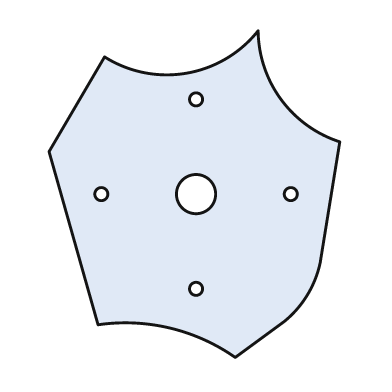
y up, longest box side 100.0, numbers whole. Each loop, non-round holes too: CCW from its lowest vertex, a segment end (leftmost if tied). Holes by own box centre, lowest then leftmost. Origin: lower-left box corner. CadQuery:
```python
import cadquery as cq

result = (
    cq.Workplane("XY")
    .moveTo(57.0, 0.0)
    .lineTo(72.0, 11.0)
    .threePointArc((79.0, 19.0), (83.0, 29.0))
    .lineTo(89.0, 66.0)
    .threePointArc((71.0, 79.0), (64.0, 100.0))
    .threePointArc((42.0, 87.0), (17.0, 92.0))
    .lineTo(0.0, 63.0)
    .lineTo(15.0, 10.0)
    .threePointArc((37.0, 9.0), (57.0, 0.0))
    .close()
    .moveTo(45.0, 21.0)
    .circle(2.0)
    .moveTo(16.0, 50.0)
    .circle(2.0)
    .moveTo(45.0, 50.0)
    .circle(6.0)
    .moveTo(74.0, 50.0)
    .circle(2.0)
    .moveTo(45.0, 79.0)
    .circle(2.0)
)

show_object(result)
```